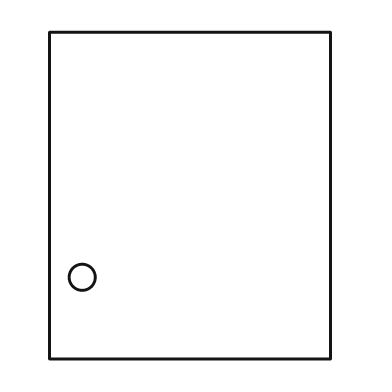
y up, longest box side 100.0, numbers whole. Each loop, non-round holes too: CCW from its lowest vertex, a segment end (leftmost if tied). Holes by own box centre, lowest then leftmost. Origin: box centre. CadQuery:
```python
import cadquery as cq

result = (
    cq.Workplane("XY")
    .moveTo(-43.0, -50.0)
    .lineTo(43.0, -50.0)
    .lineTo(43.0, 50.0)
    .lineTo(-43.0, 50.0)
    .close()
    .moveTo(-33.0, -25.0)
    .circle(4.0)
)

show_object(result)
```